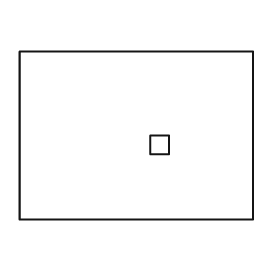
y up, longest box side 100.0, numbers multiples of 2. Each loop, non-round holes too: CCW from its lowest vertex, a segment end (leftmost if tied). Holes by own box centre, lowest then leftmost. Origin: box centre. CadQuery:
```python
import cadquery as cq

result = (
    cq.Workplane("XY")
    .moveTo(-50.0, -36.0)
    .lineTo(50.0, -36.0)
    .lineTo(50.0, 36.0)
    .lineTo(-50.0, 36.0)
    .close()
    .moveTo(6.0, -8.0)
    .lineTo(14.0, -8.0)
    .lineTo(14.0, 0.0)
    .lineTo(6.0, 0.0)
    .close()
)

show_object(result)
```